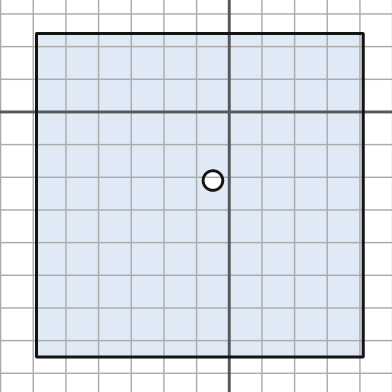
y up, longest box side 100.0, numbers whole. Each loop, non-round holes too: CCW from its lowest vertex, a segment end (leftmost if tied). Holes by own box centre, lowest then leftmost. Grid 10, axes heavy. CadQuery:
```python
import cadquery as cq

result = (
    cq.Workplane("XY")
    .moveTo(-59.0, -75.0)
    .lineTo(41.0, -75.0)
    .lineTo(41.0, 24.0)
    .lineTo(-59.0, 24.0)
    .close()
    .moveTo(-5.0, -21.0)
    .circle(3.0)
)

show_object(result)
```